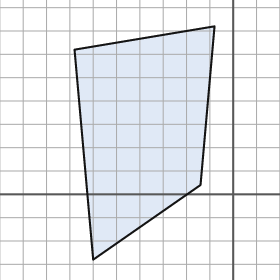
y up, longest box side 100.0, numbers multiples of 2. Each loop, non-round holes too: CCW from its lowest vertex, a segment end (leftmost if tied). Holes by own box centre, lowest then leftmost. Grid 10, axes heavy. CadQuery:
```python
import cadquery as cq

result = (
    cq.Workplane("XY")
    .moveTo(-60.0, -28.0)
    .lineTo(-14.0, 4.0)
    .lineTo(-8.0, 72.0)
    .lineTo(-68.0, 62.0)
    .close()
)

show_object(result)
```